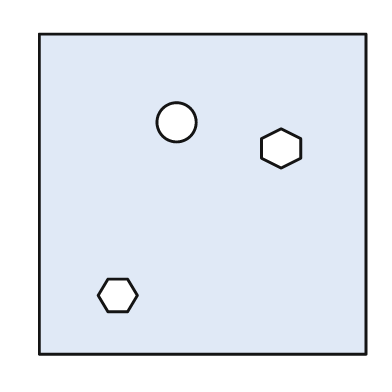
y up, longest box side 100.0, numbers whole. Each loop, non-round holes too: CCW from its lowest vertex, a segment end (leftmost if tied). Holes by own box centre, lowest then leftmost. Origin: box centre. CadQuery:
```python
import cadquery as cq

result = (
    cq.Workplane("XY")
    .moveTo(-50.0, -49.0)
    .lineTo(50.0, -49.0)
    .lineTo(50.0, 49.0)
    .lineTo(-50.0, 49.0)
    .close()
    .moveTo(-29.0, -36.0)
    .lineTo(-23.0, -36.0)
    .lineTo(-20.0, -31.0)
    .lineTo(-23.0, -26.0)
    .lineTo(-29.0, -26.0)
    .lineTo(-32.0, -31.0)
    .close()
    .moveTo(24.0, 8.0)
    .lineTo(30.0, 11.0)
    .lineTo(30.0, 17.0)
    .lineTo(24.0, 20.0)
    .lineTo(18.0, 17.0)
    .lineTo(18.0, 11.0)
    .close()
    .moveTo(-8.0, 22.0)
    .circle(6.0)
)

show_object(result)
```